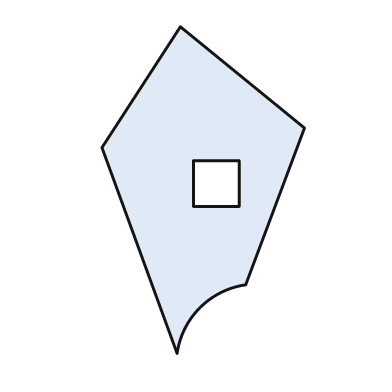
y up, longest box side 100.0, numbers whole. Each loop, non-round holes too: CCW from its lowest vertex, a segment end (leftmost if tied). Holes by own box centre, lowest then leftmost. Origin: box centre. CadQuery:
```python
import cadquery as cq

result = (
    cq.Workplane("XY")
    .moveTo(-8.0, -50.0)
    .threePointArc((-1.0, -36.0), (13.0, -29.0))
    .lineTo(31.0, 19.0)
    .lineTo(-7.0, 50.0)
    .lineTo(-31.0, 13.0)
    .close()
    .moveTo(-3.0, -5.0)
    .lineTo(11.0, -5.0)
    .lineTo(11.0, 9.0)
    .lineTo(-3.0, 9.0)
    .close()
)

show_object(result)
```